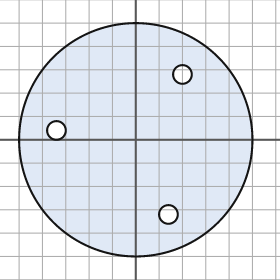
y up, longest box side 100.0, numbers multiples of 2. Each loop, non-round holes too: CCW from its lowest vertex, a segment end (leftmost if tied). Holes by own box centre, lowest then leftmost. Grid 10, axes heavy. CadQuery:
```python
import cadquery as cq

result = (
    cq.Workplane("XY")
    .moveTo(0.0, 0.0)
    .circle(50.0)
    .moveTo(14.0, -32.0)
    .circle(4.0)
    .moveTo(-34.0, 4.0)
    .circle(4.0)
    .moveTo(20.0, 28.0)
    .circle(4.0)
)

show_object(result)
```